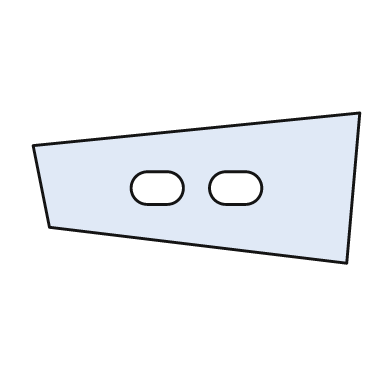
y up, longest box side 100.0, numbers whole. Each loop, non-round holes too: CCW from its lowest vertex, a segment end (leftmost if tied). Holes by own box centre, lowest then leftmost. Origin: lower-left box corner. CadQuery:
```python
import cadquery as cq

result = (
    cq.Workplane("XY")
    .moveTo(96.0, 0.0)
    .lineTo(100.0, 46.0)
    .lineTo(0.0, 36.0)
    .lineTo(5.0, 11.0)
    .close()
    .moveTo(35.0, 18.0)
    .lineTo(41.0, 18.0)
    .threePointArc((46.0, 23.0), (41.0, 28.0))
    .lineTo(35.0, 28.0)
    .threePointArc((30.0, 23.0), (35.0, 18.0))
    .close()
    .moveTo(59.0, 18.0)
    .lineTo(65.0, 18.0)
    .threePointArc((70.0, 23.0), (65.0, 28.0))
    .lineTo(59.0, 28.0)
    .threePointArc((54.0, 23.0), (59.0, 18.0))
    .close()
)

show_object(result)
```